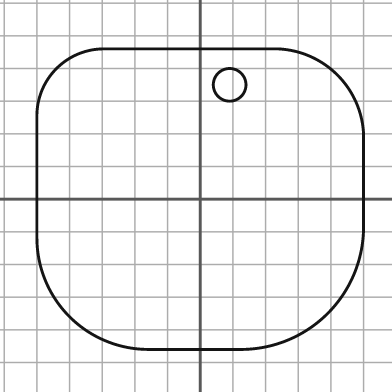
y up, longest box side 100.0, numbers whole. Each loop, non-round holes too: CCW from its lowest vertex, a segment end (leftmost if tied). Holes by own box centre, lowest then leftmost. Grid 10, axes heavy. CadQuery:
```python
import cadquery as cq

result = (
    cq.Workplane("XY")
    .moveTo(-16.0, -46.0)
    .lineTo(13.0, -46.0)
    .threePointArc((39.0, -35.0), (50.0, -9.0))
    .lineTo(50.0, 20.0)
    .threePointArc((42.0, 38.0), (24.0, 46.0))
    .lineTo(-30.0, 46.0)
    .threePointArc((-44.0, 40.0), (-50.0, 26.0))
    .lineTo(-50.0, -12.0)
    .threePointArc((-40.0, -36.0), (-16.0, -46.0))
    .close()
    .moveTo(9.0, 35.0)
    .circle(5.0)
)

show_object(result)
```